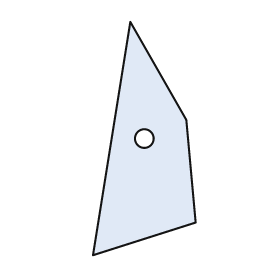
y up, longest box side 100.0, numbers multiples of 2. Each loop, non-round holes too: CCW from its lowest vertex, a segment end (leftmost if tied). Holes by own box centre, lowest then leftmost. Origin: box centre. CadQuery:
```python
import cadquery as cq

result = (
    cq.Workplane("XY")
    .moveTo(-22.0, -50.0)
    .lineTo(22.0, -36.0)
    .lineTo(18.0, 8.0)
    .lineTo(-6.0, 50.0)
    .close()
    .moveTo(0.0, 0.0)
    .circle(4.0)
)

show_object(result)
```